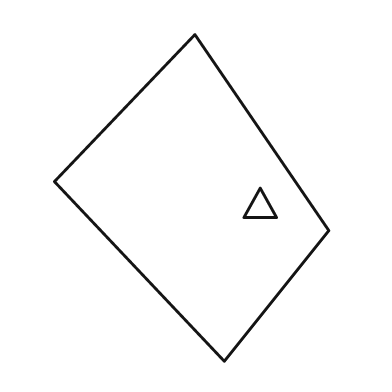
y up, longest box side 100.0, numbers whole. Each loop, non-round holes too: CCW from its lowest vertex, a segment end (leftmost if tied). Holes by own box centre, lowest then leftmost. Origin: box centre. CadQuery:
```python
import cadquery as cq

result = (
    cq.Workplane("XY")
    .moveTo(10.0, -50.0)
    .lineTo(42.0, -10.0)
    .lineTo(1.0, 50.0)
    .lineTo(-42.0, 5.0)
    .close()
    .moveTo(16.0, -6.0)
    .lineTo(26.0, -6.0)
    .lineTo(21.0, 3.0)
    .close()
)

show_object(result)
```